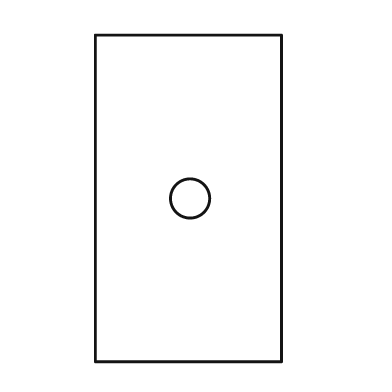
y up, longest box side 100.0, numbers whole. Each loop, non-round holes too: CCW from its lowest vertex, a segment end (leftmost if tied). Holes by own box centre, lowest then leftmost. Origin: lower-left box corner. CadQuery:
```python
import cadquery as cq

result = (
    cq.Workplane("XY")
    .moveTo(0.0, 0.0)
    .lineTo(57.0, 0.0)
    .lineTo(57.0, 100.0)
    .lineTo(0.0, 100.0)
    .close()
    .moveTo(29.0, 50.0)
    .circle(6.0)
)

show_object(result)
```